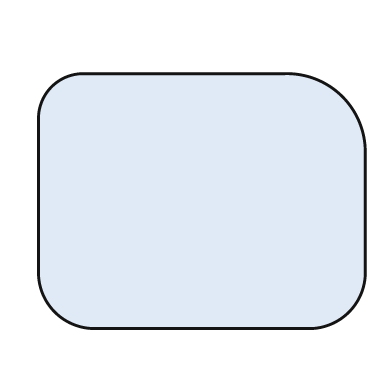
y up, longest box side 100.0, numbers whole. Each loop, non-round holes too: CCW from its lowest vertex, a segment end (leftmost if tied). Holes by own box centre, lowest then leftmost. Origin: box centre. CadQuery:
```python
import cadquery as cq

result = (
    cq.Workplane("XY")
    .moveTo(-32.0, -39.0)
    .lineTo(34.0, -39.0)
    .threePointArc((45.0, -34.0), (50.0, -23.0))
    .lineTo(50.0, 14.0)
    .threePointArc((43.0, 32.0), (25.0, 39.0))
    .lineTo(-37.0, 39.0)
    .threePointArc((-46.0, 35.0), (-50.0, 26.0))
    .lineTo(-50.0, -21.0)
    .threePointArc((-45.0, -34.0), (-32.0, -39.0))
    .close()
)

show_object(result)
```